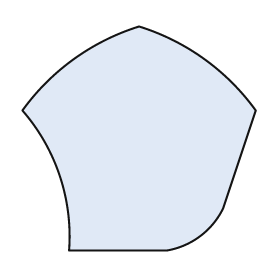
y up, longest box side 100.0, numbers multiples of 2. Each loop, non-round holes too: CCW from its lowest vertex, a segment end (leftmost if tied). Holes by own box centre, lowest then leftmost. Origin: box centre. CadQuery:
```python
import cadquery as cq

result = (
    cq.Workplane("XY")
    .moveTo(-30.0, -48.0)
    .lineTo(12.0, -48.0)
    .threePointArc((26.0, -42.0), (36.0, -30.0))
    .lineTo(50.0, 12.0)
    .threePointArc((28.0, 34.0), (0.0, 48.0))
    .threePointArc((-28.0, 34.0), (-50.0, 12.0))
    .threePointArc((-34.0, -16.0), (-30.0, -48.0))
    .close()
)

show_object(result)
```